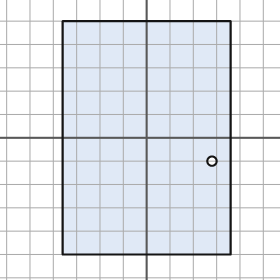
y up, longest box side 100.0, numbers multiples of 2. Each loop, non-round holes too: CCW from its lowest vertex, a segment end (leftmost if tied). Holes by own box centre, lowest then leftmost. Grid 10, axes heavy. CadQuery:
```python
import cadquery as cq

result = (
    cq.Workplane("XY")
    .moveTo(-36.0, -50.0)
    .lineTo(36.0, -50.0)
    .lineTo(36.0, 50.0)
    .lineTo(-36.0, 50.0)
    .close()
    .moveTo(28.0, -10.0)
    .circle(2.0)
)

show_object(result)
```